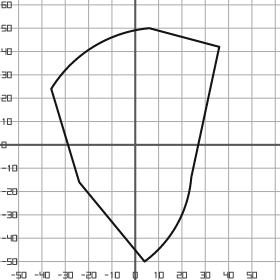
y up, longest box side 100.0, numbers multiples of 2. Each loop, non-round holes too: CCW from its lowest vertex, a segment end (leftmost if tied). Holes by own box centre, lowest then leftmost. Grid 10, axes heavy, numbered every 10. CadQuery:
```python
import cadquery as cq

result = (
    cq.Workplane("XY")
    .moveTo(4.0, -50.0)
    .threePointArc((18.0, -34.0), (24.0, -14.0))
    .lineTo(36.0, 42.0)
    .lineTo(6.0, 50.0)
    .threePointArc((-18.0, 42.0), (-36.0, 24.0))
    .lineTo(-24.0, -16.0)
    .close()
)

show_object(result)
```